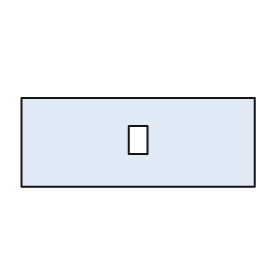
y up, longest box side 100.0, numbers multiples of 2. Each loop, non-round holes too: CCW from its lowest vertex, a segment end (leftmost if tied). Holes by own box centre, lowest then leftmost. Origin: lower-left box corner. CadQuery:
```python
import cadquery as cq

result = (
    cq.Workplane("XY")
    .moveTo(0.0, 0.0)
    .lineTo(100.0, 0.0)
    .lineTo(100.0, 38.0)
    .lineTo(0.0, 38.0)
    .close()
    .moveTo(46.0, 14.0)
    .lineTo(54.0, 14.0)
    .lineTo(54.0, 26.0)
    .lineTo(46.0, 26.0)
    .close()
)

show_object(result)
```